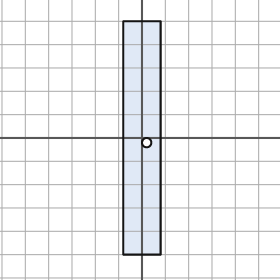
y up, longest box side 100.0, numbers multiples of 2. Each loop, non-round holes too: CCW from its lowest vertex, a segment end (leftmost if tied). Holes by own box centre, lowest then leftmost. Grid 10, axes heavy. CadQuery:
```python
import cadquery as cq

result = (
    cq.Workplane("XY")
    .moveTo(-8.0, -50.0)
    .lineTo(8.0, -50.0)
    .lineTo(8.0, 50.0)
    .lineTo(-8.0, 50.0)
    .close()
    .moveTo(2.0, -2.0)
    .circle(2.0)
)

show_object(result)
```